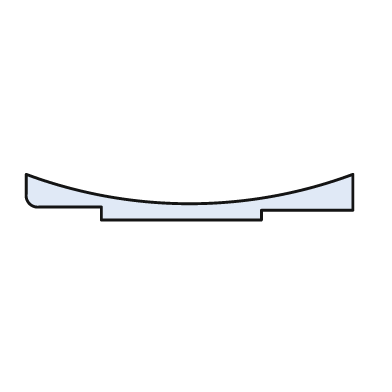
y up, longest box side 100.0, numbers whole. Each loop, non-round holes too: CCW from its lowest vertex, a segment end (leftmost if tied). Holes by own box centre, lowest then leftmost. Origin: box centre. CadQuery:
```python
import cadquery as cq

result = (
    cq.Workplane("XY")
    .moveTo(-27.0, -7.0)
    .lineTo(22.0, -7.0)
    .lineTo(22.0, -4.0)
    .lineTo(50.0, -4.0)
    .lineTo(50.0, 7.0)
    .threePointArc((0.0, -2.0), (-50.0, 7.0))
    .lineTo(-50.0, 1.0)
    .threePointArc((-49.0, -2.0), (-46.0, -3.0))
    .lineTo(-27.0, -3.0)
    .close()
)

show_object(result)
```